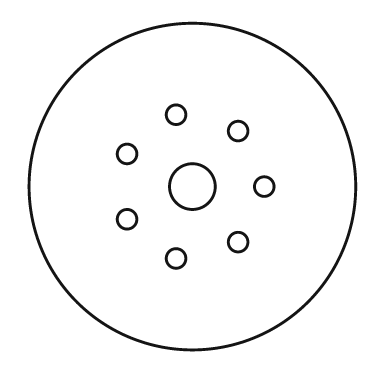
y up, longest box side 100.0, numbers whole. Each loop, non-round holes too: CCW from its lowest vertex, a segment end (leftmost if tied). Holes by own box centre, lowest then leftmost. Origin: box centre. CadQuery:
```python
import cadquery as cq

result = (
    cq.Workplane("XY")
    .moveTo(0.0, 0.0)
    .circle(50.0)
    .moveTo(-5.0, -22.0)
    .circle(3.0)
    .moveTo(14.0, -17.0)
    .circle(3.0)
    .moveTo(-20.0, -10.0)
    .circle(3.0)
    .moveTo(0.0, 0.0)
    .circle(7.0)
    .moveTo(22.0, 0.0)
    .circle(3.0)
    .moveTo(-20.0, 10.0)
    .circle(3.0)
    .moveTo(14.0, 17.0)
    .circle(3.0)
    .moveTo(-5.0, 22.0)
    .circle(3.0)
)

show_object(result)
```